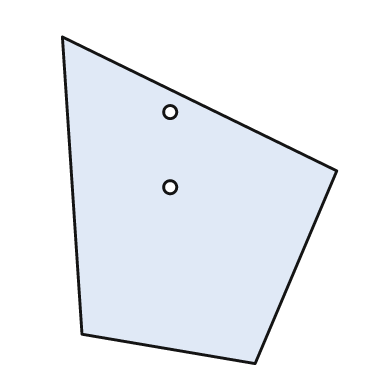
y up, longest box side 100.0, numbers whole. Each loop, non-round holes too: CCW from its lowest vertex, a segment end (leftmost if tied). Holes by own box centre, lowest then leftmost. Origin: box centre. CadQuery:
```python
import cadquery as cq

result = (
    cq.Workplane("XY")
    .moveTo(17.0, -50.0)
    .lineTo(42.0, 9.0)
    .lineTo(-42.0, 50.0)
    .lineTo(-36.0, -41.0)
    .close()
    .moveTo(-9.0, 4.0)
    .circle(2.0)
    .moveTo(-9.0, 27.0)
    .circle(2.0)
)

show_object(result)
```